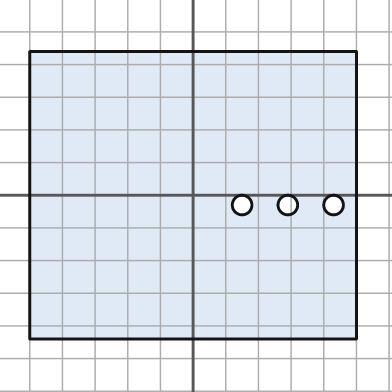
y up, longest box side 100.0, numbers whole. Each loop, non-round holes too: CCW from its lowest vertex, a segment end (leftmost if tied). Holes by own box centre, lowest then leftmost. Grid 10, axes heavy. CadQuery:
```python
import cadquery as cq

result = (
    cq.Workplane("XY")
    .moveTo(-50.0, -44.0)
    .lineTo(50.0, -44.0)
    .lineTo(50.0, 44.0)
    .lineTo(-50.0, 44.0)
    .close()
    .moveTo(15.0, -3.0)
    .circle(3.0)
    .moveTo(29.0, -3.0)
    .circle(3.0)
    .moveTo(43.0, -3.0)
    .circle(3.0)
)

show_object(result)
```